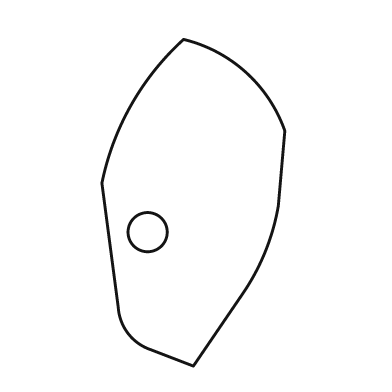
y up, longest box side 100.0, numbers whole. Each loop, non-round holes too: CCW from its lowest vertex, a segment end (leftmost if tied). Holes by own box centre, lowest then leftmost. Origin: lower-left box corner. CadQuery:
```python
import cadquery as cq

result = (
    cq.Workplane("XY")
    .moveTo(28.0, 0.0)
    .lineTo(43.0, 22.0)
    .threePointArc((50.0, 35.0), (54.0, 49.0))
    .lineTo(56.0, 72.0)
    .threePointArc((44.0, 90.0), (25.0, 100.0))
    .threePointArc((9.0, 80.0), (0.0, 56.0))
    .lineTo(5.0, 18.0)
    .threePointArc((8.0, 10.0), (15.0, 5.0))
    .close()
    .moveTo(14.0, 41.0)
    .circle(6.0)
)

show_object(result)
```